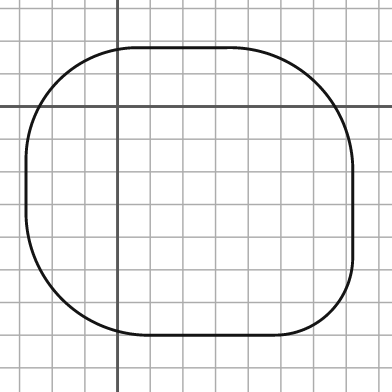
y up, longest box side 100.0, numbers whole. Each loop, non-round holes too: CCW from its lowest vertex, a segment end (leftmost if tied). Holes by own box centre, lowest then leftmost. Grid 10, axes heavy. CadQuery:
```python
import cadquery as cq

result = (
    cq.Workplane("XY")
    .moveTo(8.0, -70.0)
    .lineTo(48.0, -70.0)
    .threePointArc((65.0, -63.0), (72.0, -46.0))
    .lineTo(72.0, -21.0)
    .threePointArc((61.0, 7.0), (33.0, 18.0))
    .lineTo(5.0, 18.0)
    .threePointArc((-18.0, 8.0), (-28.0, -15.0))
    .lineTo(-28.0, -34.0)
    .threePointArc((-17.0, -59.0), (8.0, -70.0))
    .close()
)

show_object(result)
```